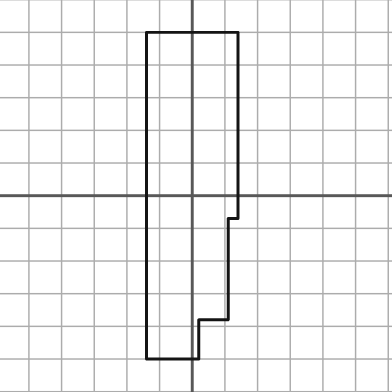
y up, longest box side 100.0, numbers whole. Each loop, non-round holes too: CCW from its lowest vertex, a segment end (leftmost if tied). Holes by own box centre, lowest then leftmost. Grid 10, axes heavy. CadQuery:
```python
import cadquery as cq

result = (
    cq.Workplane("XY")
    .moveTo(-14.0, -50.0)
    .lineTo(2.0, -50.0)
    .lineTo(2.0, -38.0)
    .lineTo(11.0, -38.0)
    .lineTo(11.0, -7.0)
    .lineTo(14.0, -7.0)
    .lineTo(14.0, 50.0)
    .lineTo(-14.0, 50.0)
    .close()
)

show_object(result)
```